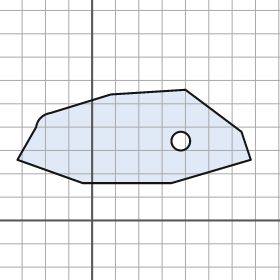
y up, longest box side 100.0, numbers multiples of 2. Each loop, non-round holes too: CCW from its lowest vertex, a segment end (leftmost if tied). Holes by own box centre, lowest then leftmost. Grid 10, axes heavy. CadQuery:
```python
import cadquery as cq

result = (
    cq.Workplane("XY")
    .moveTo(-4.0, 16.0)
    .lineTo(34.0, 16.0)
    .lineTo(68.0, 26.0)
    .lineTo(64.0, 38.0)
    .lineTo(40.0, 56.0)
    .lineTo(8.0, 54.0)
    .lineTo(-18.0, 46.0)
    .threePointArc((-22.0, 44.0), (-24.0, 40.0))
    .lineTo(-32.0, 26.0)
    .close()
    .moveTo(38.0, 34.0)
    .circle(4.0)
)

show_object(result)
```